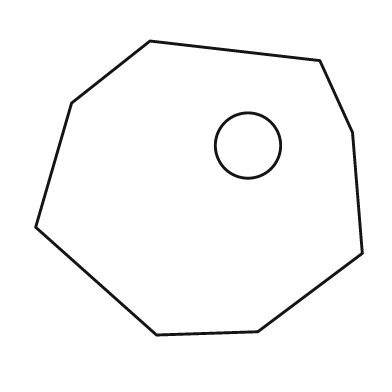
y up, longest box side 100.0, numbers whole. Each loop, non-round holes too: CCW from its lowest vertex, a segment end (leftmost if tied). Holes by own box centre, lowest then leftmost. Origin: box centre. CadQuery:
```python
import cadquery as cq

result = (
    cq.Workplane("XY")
    .moveTo(-13.0, -45.0)
    .lineTo(18.0, -44.0)
    .lineTo(50.0, -20.0)
    .lineTo(47.0, 17.0)
    .lineTo(37.0, 39.0)
    .lineTo(-15.0, 45.0)
    .lineTo(-39.0, 26.0)
    .lineTo(-50.0, -12.0)
    .close()
    .moveTo(15.0, 13.0)
    .circle(10.0)
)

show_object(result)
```